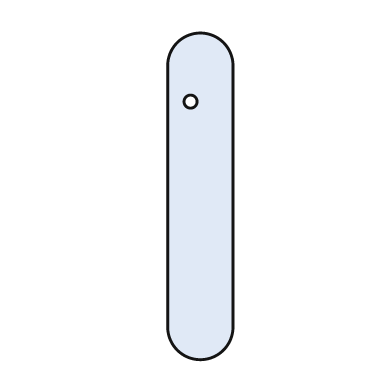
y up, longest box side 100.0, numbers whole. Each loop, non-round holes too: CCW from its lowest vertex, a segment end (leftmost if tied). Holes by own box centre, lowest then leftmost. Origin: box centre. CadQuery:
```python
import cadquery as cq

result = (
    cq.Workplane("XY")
    .moveTo(-10.0, -40.0)
    .threePointArc((0.0, -50.0), (10.0, -40.0))
    .lineTo(10.0, 40.0)
    .threePointArc((0.0, 50.0), (-10.0, 40.0))
    .close()
    .moveTo(-3.0, 29.0)
    .circle(2.0)
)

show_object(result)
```